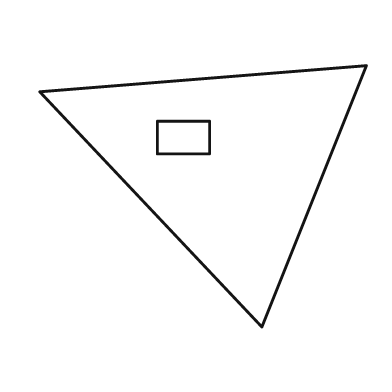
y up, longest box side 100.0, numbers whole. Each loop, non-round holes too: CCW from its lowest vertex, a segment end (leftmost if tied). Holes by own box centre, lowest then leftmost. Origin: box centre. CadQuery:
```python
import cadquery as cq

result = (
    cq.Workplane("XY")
    .moveTo(18.0, -40.0)
    .lineTo(50.0, 40.0)
    .lineTo(-50.0, 32.0)
    .close()
    .moveTo(-14.0, 13.0)
    .lineTo(2.0, 13.0)
    .lineTo(2.0, 23.0)
    .lineTo(-14.0, 23.0)
    .close()
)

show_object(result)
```